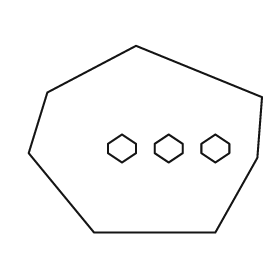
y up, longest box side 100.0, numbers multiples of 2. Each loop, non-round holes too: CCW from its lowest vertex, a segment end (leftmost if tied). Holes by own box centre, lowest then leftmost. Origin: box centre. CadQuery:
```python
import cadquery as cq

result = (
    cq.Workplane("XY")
    .moveTo(-22.0, -40.0)
    .lineTo(30.0, -40.0)
    .lineTo(48.0, -8.0)
    .lineTo(50.0, 18.0)
    .lineTo(-4.0, 40.0)
    .lineTo(-42.0, 20.0)
    .lineTo(-50.0, -6.0)
    .close()
    .moveTo(-10.0, -10.0)
    .lineTo(-4.0, -6.0)
    .lineTo(-4.0, -2.0)
    .lineTo(-10.0, 2.0)
    .lineTo(-16.0, -2.0)
    .lineTo(-16.0, -6.0)
    .close()
    .moveTo(10.0, -10.0)
    .lineTo(16.0, -6.0)
    .lineTo(16.0, -2.0)
    .lineTo(10.0, 2.0)
    .lineTo(4.0, -2.0)
    .lineTo(4.0, -6.0)
    .close()
    .moveTo(30.0, -10.0)
    .lineTo(36.0, -6.0)
    .lineTo(36.0, -2.0)
    .lineTo(30.0, 2.0)
    .lineTo(24.0, -2.0)
    .lineTo(24.0, -6.0)
    .close()
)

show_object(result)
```